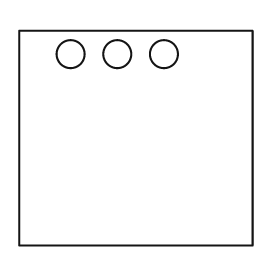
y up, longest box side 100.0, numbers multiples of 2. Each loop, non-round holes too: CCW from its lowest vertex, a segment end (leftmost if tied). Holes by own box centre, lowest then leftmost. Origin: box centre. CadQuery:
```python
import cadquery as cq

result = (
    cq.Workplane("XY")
    .moveTo(-50.0, -46.0)
    .lineTo(50.0, -46.0)
    .lineTo(50.0, 46.0)
    .lineTo(-50.0, 46.0)
    .close()
    .moveTo(-28.0, 36.0)
    .circle(6.0)
    .moveTo(-8.0, 36.0)
    .circle(6.0)
    .moveTo(12.0, 36.0)
    .circle(6.0)
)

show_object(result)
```